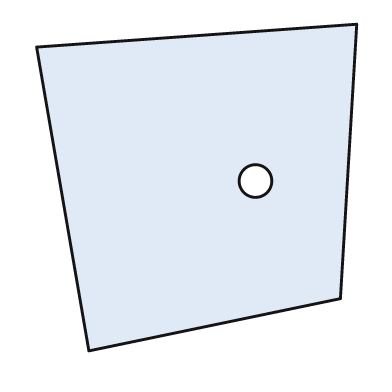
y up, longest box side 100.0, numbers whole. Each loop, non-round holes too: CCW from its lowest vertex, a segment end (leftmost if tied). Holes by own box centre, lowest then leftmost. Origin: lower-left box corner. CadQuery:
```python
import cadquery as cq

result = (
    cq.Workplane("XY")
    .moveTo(16.0, 0.0)
    .lineTo(93.0, 16.0)
    .lineTo(98.0, 100.0)
    .lineTo(0.0, 93.0)
    .close()
    .moveTo(67.0, 52.0)
    .circle(5.0)
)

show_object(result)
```